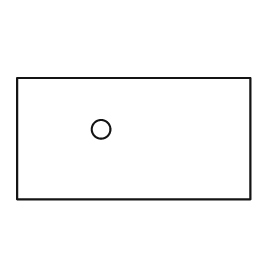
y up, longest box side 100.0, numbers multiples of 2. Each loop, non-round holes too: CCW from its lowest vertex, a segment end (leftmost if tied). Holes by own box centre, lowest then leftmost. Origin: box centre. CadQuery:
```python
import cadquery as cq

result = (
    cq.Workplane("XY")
    .moveTo(-50.0, -26.0)
    .lineTo(50.0, -26.0)
    .lineTo(50.0, 26.0)
    .lineTo(-50.0, 26.0)
    .close()
    .moveTo(-14.0, 4.0)
    .circle(4.0)
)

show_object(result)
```